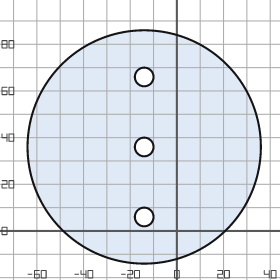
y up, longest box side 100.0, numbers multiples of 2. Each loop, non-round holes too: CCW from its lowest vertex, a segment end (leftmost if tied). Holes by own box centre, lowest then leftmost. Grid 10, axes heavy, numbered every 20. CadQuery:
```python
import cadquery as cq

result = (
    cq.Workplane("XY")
    .moveTo(-14.0, 36.0)
    .circle(50.0)
    .moveTo(-14.0, 6.0)
    .circle(4.0)
    .moveTo(-14.0, 36.0)
    .circle(4.0)
    .moveTo(-14.0, 66.0)
    .circle(4.0)
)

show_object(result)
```